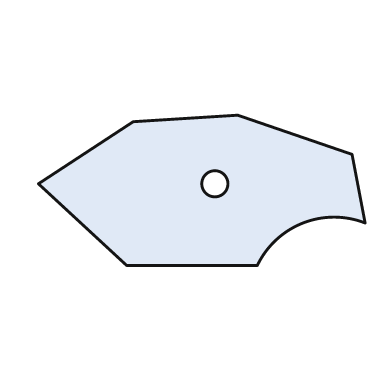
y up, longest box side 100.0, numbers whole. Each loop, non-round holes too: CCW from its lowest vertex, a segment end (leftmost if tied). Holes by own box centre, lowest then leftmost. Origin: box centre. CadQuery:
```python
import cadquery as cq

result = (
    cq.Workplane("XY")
    .moveTo(-23.0, -23.0)
    .lineTo(17.0, -23.0)
    .threePointArc((31.0, -10.0), (50.0, -10.0))
    .lineTo(46.0, 11.0)
    .lineTo(11.0, 23.0)
    .lineTo(-21.0, 21.0)
    .lineTo(-50.0, 2.0)
    .close()
    .moveTo(4.0, 2.0)
    .circle(4.0)
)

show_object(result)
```